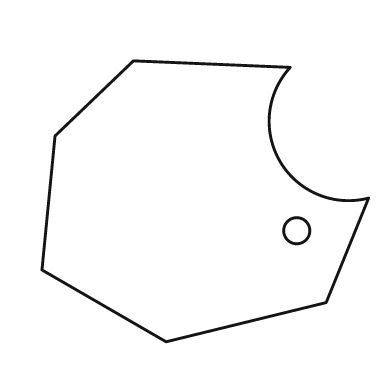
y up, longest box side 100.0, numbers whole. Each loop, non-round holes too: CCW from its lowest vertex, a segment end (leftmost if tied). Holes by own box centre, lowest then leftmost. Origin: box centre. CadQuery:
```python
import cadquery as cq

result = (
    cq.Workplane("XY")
    .moveTo(-12.0, -43.0)
    .lineTo(37.0, -31.0)
    .lineTo(50.0, 1.0)
    .threePointArc((23.0, 12.0), (26.0, 41.0))
    .lineTo(-22.0, 43.0)
    .lineTo(-46.0, 20.0)
    .lineTo(-50.0, -21.0)
    .close()
    .moveTo(28.0, -9.0)
    .circle(4.0)
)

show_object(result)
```